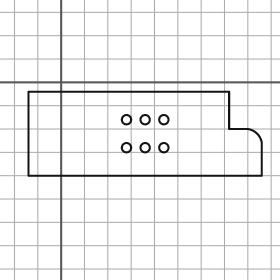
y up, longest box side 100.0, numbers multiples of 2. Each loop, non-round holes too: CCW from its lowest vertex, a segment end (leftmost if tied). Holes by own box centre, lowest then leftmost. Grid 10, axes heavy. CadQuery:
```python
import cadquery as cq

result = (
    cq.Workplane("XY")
    .moveTo(-14.0, -40.0)
    .lineTo(86.0, -40.0)
    .lineTo(86.0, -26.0)
    .threePointArc((84.0, -22.0), (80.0, -20.0))
    .lineTo(72.0, -20.0)
    .lineTo(72.0, -4.0)
    .lineTo(-14.0, -4.0)
    .close()
    .moveTo(28.0, -28.0)
    .circle(2.0)
    .moveTo(36.0, -28.0)
    .circle(2.0)
    .moveTo(44.0, -28.0)
    .circle(2.0)
    .moveTo(28.0, -16.0)
    .circle(2.0)
    .moveTo(36.0, -16.0)
    .circle(2.0)
    .moveTo(44.0, -16.0)
    .circle(2.0)
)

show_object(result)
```